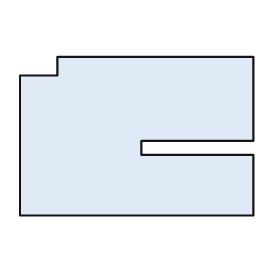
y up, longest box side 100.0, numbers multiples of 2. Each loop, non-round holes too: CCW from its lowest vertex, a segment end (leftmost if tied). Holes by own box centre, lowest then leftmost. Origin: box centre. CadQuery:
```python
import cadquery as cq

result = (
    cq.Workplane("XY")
    .moveTo(-50.0, -34.0)
    .lineTo(50.0, -34.0)
    .lineTo(50.0, -8.0)
    .lineTo(2.0, -8.0)
    .lineTo(2.0, -2.0)
    .lineTo(50.0, -2.0)
    .lineTo(50.0, 34.0)
    .lineTo(-34.0, 34.0)
    .lineTo(-34.0, 26.0)
    .lineTo(-50.0, 26.0)
    .close()
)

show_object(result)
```